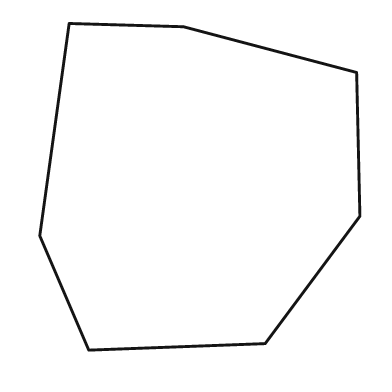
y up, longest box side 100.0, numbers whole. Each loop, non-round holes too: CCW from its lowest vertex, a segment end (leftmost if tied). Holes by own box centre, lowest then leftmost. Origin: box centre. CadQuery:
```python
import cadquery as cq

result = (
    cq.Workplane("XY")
    .moveTo(-34.0, -50.0)
    .lineTo(20.0, -48.0)
    .lineTo(49.0, -9.0)
    .lineTo(48.0, 35.0)
    .lineTo(-5.0, 49.0)
    .lineTo(-40.0, 50.0)
    .lineTo(-49.0, -15.0)
    .close()
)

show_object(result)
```